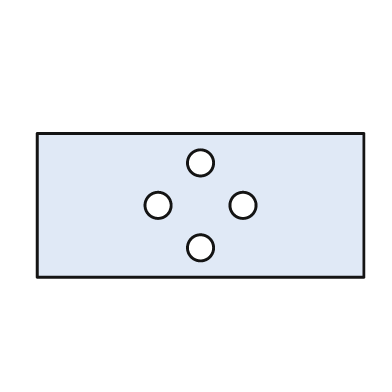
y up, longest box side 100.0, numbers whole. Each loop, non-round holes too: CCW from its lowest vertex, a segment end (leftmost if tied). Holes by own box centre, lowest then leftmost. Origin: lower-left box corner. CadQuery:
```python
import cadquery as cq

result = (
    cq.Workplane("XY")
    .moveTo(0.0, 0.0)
    .lineTo(100.0, 0.0)
    .lineTo(100.0, 44.0)
    .lineTo(0.0, 44.0)
    .close()
    .moveTo(50.0, 9.0)
    .circle(4.0)
    .moveTo(37.0, 22.0)
    .circle(4.0)
    .moveTo(63.0, 22.0)
    .circle(4.0)
    .moveTo(50.0, 35.0)
    .circle(4.0)
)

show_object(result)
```